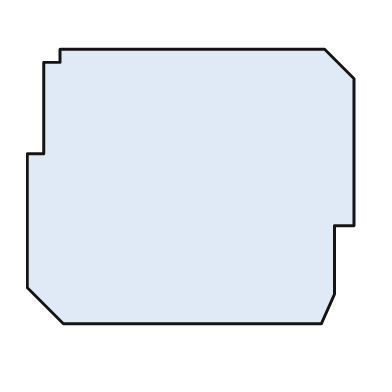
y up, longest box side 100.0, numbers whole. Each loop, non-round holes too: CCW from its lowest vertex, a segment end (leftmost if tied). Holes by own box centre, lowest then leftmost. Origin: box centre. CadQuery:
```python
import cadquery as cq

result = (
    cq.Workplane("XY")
    .moveTo(-39.0, -42.0)
    .lineTo(40.0, -42.0)
    .lineTo(44.0, -33.0)
    .lineTo(44.0, -12.0)
    .lineTo(50.0, -12.0)
    .lineTo(50.0, 33.0)
    .lineTo(41.0, 42.0)
    .lineTo(-40.0, 42.0)
    .lineTo(-40.0, 38.0)
    .lineTo(-45.0, 38.0)
    .lineTo(-45.0, 10.0)
    .lineTo(-50.0, 10.0)
    .lineTo(-50.0, -31.0)
    .close()
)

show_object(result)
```